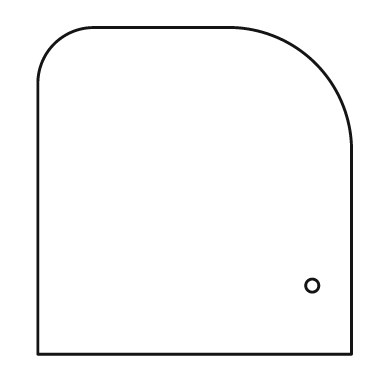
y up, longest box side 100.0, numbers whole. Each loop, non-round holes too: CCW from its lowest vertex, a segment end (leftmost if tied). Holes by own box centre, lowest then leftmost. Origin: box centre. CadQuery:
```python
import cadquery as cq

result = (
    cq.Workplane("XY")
    .moveTo(-48.0, -50.0)
    .lineTo(48.0, -50.0)
    .lineTo(48.0, 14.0)
    .threePointArc((37.0, 39.0), (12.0, 50.0))
    .lineTo(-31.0, 50.0)
    .threePointArc((-43.0, 45.0), (-48.0, 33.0))
    .close()
    .moveTo(36.0, -29.0)
    .circle(2.0)
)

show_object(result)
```